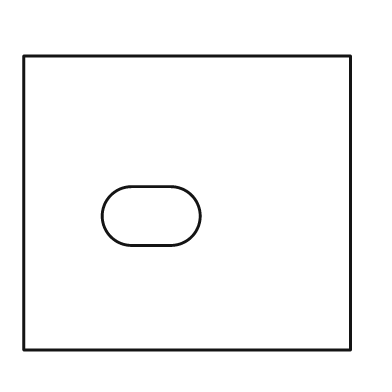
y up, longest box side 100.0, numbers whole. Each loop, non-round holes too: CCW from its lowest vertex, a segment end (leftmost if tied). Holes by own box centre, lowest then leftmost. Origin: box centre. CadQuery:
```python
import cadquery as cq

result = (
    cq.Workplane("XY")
    .moveTo(-50.0, -45.0)
    .lineTo(50.0, -45.0)
    .lineTo(50.0, 45.0)
    .lineTo(-50.0, 45.0)
    .close()
    .moveTo(-17.0, -13.0)
    .lineTo(-5.0, -13.0)
    .threePointArc((4.0, -4.0), (-5.0, 5.0))
    .lineTo(-17.0, 5.0)
    .threePointArc((-26.0, -4.0), (-17.0, -13.0))
    .close()
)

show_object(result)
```